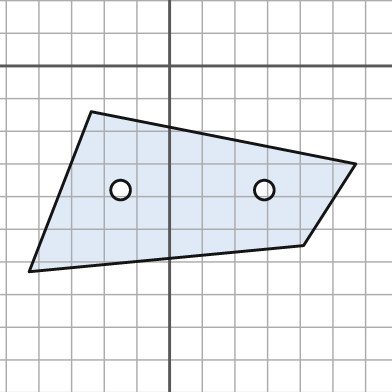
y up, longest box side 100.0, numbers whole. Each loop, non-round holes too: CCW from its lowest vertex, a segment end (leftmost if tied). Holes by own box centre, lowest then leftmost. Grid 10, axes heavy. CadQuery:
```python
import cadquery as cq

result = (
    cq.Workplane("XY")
    .moveTo(-43.0, -63.0)
    .lineTo(41.0, -55.0)
    .lineTo(57.0, -30.0)
    .lineTo(-24.0, -14.0)
    .close()
    .moveTo(-15.0, -38.0)
    .circle(3.0)
    .moveTo(29.0, -38.0)
    .circle(3.0)
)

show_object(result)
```